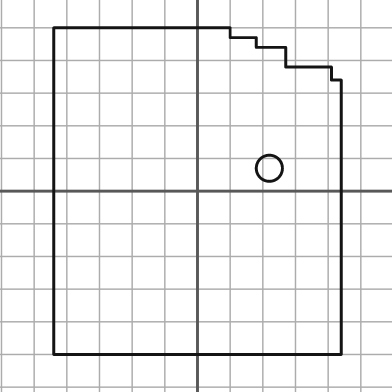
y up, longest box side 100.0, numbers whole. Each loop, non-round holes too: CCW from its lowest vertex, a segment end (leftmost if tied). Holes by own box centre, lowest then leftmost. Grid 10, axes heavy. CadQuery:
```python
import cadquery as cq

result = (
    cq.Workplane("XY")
    .moveTo(-44.0, -50.0)
    .lineTo(44.0, -50.0)
    .lineTo(44.0, 34.0)
    .lineTo(41.0, 34.0)
    .lineTo(41.0, 38.0)
    .lineTo(27.0, 38.0)
    .lineTo(27.0, 44.0)
    .lineTo(18.0, 44.0)
    .lineTo(18.0, 47.0)
    .lineTo(10.0, 47.0)
    .lineTo(10.0, 50.0)
    .lineTo(-44.0, 50.0)
    .close()
    .moveTo(22.0, 7.0)
    .circle(4.0)
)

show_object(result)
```